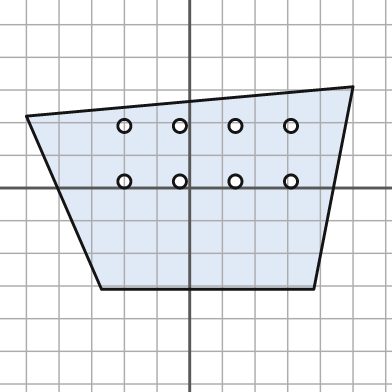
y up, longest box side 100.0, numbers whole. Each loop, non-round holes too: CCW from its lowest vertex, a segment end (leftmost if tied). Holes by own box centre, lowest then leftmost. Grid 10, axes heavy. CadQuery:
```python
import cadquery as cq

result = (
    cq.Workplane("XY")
    .moveTo(-27.0, -31.0)
    .lineTo(38.0, -31.0)
    .lineTo(50.0, 31.0)
    .lineTo(-50.0, 22.0)
    .close()
    .moveTo(-20.0, 2.0)
    .circle(2.0)
    .moveTo(-3.0, 2.0)
    .circle(2.0)
    .moveTo(14.0, 2.0)
    .circle(2.0)
    .moveTo(31.0, 2.0)
    .circle(2.0)
    .moveTo(-20.0, 19.0)
    .circle(2.0)
    .moveTo(-3.0, 19.0)
    .circle(2.0)
    .moveTo(14.0, 19.0)
    .circle(2.0)
    .moveTo(31.0, 19.0)
    .circle(2.0)
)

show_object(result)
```